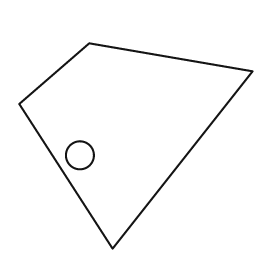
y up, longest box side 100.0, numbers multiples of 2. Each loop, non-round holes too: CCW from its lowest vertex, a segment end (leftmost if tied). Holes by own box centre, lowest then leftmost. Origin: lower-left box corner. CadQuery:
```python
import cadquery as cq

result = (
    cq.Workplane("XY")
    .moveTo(40.0, 0.0)
    .lineTo(100.0, 76.0)
    .lineTo(30.0, 88.0)
    .lineTo(0.0, 62.0)
    .close()
    .moveTo(26.0, 40.0)
    .circle(6.0)
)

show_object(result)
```